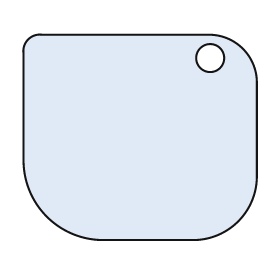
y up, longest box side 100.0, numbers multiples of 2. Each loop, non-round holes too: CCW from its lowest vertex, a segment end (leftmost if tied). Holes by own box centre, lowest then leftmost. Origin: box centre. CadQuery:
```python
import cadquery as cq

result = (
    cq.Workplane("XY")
    .moveTo(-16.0, -44.0)
    .lineTo(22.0, -44.0)
    .threePointArc((42.0, -36.0), (50.0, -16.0))
    .lineTo(50.0, 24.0)
    .threePointArc((44.0, 38.0), (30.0, 44.0))
    .lineTo(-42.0, 44.0)
    .threePointArc((-48.0, 42.0), (-50.0, 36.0))
    .lineTo(-50.0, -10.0)
    .threePointArc((-40.0, -34.0), (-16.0, -44.0))
    .close()
    .moveTo(30.0, 34.0)
    .circle(6.0)
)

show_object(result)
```